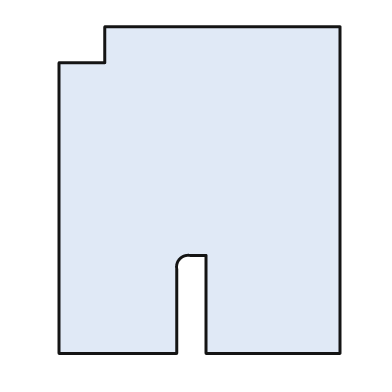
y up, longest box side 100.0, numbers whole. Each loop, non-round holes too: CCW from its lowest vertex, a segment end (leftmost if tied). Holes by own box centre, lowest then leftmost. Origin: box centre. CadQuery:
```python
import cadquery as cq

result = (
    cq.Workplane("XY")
    .moveTo(-43.0, -50.0)
    .lineTo(-7.0, -50.0)
    .lineTo(-7.0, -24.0)
    .threePointArc((-6.0, -21.0), (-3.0, -20.0))
    .lineTo(2.0, -20.0)
    .lineTo(2.0, -50.0)
    .lineTo(43.0, -50.0)
    .lineTo(43.0, 50.0)
    .lineTo(-29.0, 50.0)
    .lineTo(-29.0, 39.0)
    .lineTo(-43.0, 39.0)
    .close()
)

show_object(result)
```